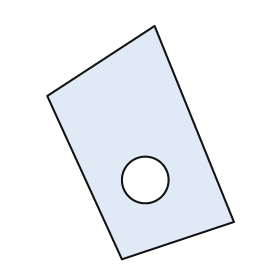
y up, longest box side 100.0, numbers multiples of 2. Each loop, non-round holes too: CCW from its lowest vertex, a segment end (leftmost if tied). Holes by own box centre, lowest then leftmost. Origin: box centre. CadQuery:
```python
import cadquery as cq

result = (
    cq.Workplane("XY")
    .moveTo(-8.0, -50.0)
    .lineTo(40.0, -34.0)
    .lineTo(6.0, 50.0)
    .lineTo(-40.0, 20.0)
    .close()
    .moveTo(2.0, -16.0)
    .circle(10.0)
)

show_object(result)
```